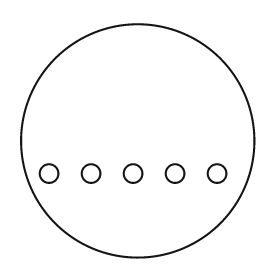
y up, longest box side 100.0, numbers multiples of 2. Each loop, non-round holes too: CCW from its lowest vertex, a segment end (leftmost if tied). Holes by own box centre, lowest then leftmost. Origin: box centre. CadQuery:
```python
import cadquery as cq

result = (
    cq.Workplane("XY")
    .moveTo(0.0, 0.0)
    .circle(50.0)
    .moveTo(-38.0, -14.0)
    .circle(4.0)
    .moveTo(-20.0, -14.0)
    .circle(4.0)
    .moveTo(-2.0, -14.0)
    .circle(4.0)
    .moveTo(16.0, -14.0)
    .circle(4.0)
    .moveTo(34.0, -14.0)
    .circle(4.0)
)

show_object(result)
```